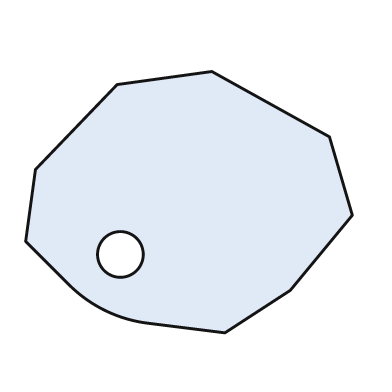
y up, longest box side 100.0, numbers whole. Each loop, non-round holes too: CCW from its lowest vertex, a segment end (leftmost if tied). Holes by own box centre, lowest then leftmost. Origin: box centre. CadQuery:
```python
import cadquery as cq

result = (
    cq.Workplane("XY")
    .moveTo(11.0, -40.0)
    .lineTo(31.0, -27.0)
    .lineTo(50.0, -4.0)
    .lineTo(43.0, 20.0)
    .lineTo(7.0, 40.0)
    .lineTo(-22.0, 36.0)
    .lineTo(-47.0, 10.0)
    .lineTo(-50.0, -12.0)
    .lineTo(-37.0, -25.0)
    .threePointArc((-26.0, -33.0), (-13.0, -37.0))
    .close()
    .moveTo(-21.0, -16.0)
    .circle(7.0)
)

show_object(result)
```